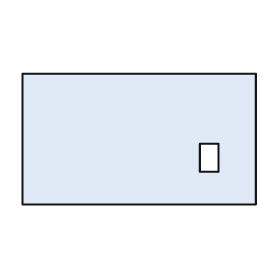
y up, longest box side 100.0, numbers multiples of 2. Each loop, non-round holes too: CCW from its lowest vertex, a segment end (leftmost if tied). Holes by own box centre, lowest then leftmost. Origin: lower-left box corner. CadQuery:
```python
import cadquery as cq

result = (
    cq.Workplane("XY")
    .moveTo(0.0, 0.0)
    .lineTo(100.0, 0.0)
    .lineTo(100.0, 56.0)
    .lineTo(0.0, 56.0)
    .close()
    .moveTo(76.0, 14.0)
    .lineTo(84.0, 14.0)
    .lineTo(84.0, 26.0)
    .lineTo(76.0, 26.0)
    .close()
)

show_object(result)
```